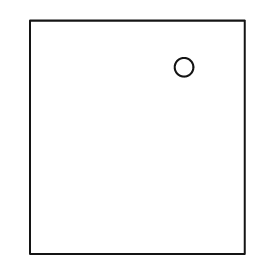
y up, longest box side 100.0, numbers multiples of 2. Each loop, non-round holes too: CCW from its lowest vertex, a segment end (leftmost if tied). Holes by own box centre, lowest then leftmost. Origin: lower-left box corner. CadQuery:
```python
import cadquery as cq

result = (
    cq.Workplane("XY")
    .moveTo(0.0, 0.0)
    .lineTo(92.0, 0.0)
    .lineTo(92.0, 100.0)
    .lineTo(0.0, 100.0)
    .close()
    .moveTo(66.0, 80.0)
    .circle(4.0)
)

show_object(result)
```